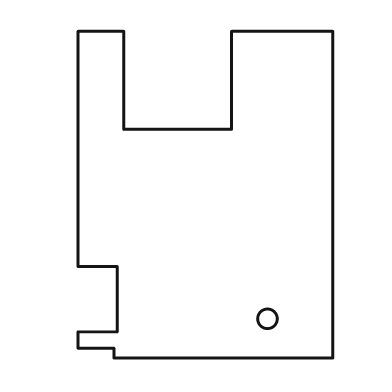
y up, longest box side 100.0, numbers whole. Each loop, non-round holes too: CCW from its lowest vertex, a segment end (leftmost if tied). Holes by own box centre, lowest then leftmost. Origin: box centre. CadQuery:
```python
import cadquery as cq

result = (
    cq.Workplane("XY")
    .moveTo(-28.0, -50.0)
    .lineTo(39.0, -50.0)
    .lineTo(39.0, 50.0)
    .lineTo(8.0, 50.0)
    .lineTo(8.0, 20.0)
    .lineTo(-25.0, 20.0)
    .lineTo(-25.0, 50.0)
    .lineTo(-39.0, 50.0)
    .lineTo(-39.0, -22.0)
    .lineTo(-27.0, -22.0)
    .lineTo(-27.0, -42.0)
    .lineTo(-39.0, -42.0)
    .lineTo(-39.0, -47.0)
    .lineTo(-28.0, -47.0)
    .close()
    .moveTo(19.0, -38.0)
    .circle(3.0)
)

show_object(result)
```